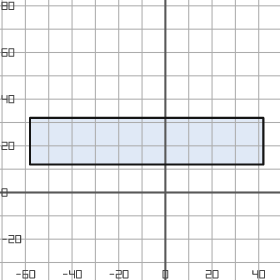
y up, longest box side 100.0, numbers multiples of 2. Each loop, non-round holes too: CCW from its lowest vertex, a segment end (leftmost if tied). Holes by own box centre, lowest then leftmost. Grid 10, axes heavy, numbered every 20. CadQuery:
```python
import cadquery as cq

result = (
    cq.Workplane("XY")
    .moveTo(-58.0, 12.0)
    .lineTo(42.0, 12.0)
    .lineTo(42.0, 32.0)
    .lineTo(-58.0, 32.0)
    .close()
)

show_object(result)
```